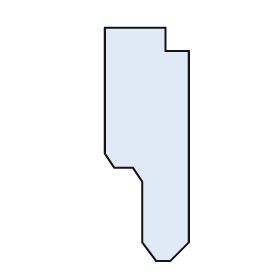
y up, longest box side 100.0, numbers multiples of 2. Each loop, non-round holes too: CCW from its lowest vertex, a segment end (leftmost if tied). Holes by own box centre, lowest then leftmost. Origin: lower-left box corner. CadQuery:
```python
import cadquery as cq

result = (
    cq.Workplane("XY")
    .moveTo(22.0, 0.0)
    .lineTo(28.0, 0.0)
    .lineTo(36.0, 8.0)
    .lineTo(36.0, 90.0)
    .lineTo(26.0, 90.0)
    .lineTo(26.0, 100.0)
    .lineTo(0.0, 100.0)
    .lineTo(0.0, 46.0)
    .lineTo(4.0, 40.0)
    .lineTo(12.0, 40.0)
    .lineTo(16.0, 34.0)
    .lineTo(16.0, 8.0)
    .close()
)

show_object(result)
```